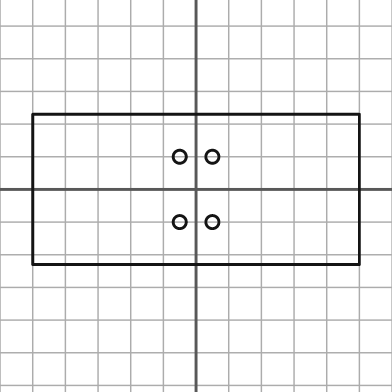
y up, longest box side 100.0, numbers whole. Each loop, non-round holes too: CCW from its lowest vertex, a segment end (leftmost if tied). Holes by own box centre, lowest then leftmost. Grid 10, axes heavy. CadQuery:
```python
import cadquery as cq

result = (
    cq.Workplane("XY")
    .moveTo(-50.0, -23.0)
    .lineTo(50.0, -23.0)
    .lineTo(50.0, 23.0)
    .lineTo(-50.0, 23.0)
    .close()
    .moveTo(-5.0, -10.0)
    .circle(2.0)
    .moveTo(5.0, -10.0)
    .circle(2.0)
    .moveTo(-5.0, 10.0)
    .circle(2.0)
    .moveTo(5.0, 10.0)
    .circle(2.0)
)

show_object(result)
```